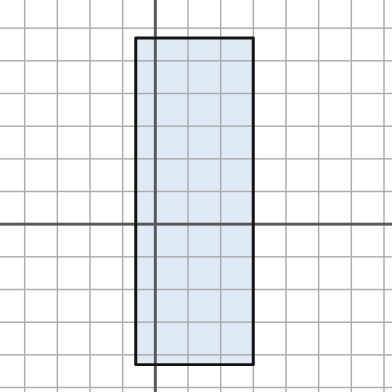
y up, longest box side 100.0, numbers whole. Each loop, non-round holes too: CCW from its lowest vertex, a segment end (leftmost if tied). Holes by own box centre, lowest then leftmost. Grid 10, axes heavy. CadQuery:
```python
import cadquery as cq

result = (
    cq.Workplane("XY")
    .moveTo(-6.0, -43.0)
    .lineTo(30.0, -43.0)
    .lineTo(30.0, 57.0)
    .lineTo(-6.0, 57.0)
    .close()
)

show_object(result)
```